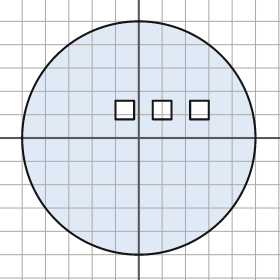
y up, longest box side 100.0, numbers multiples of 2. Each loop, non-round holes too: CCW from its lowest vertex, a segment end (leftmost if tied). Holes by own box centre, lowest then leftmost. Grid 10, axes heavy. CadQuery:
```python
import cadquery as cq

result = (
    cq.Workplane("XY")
    .moveTo(0.0, 0.0)
    .circle(50.0)
    .moveTo(-10.0, 8.0)
    .lineTo(-2.0, 8.0)
    .lineTo(-2.0, 16.0)
    .lineTo(-10.0, 16.0)
    .close()
    .moveTo(6.0, 8.0)
    .lineTo(14.0, 8.0)
    .lineTo(14.0, 16.0)
    .lineTo(6.0, 16.0)
    .close()
    .moveTo(22.0, 8.0)
    .lineTo(30.0, 8.0)
    .lineTo(30.0, 16.0)
    .lineTo(22.0, 16.0)
    .close()
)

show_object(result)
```